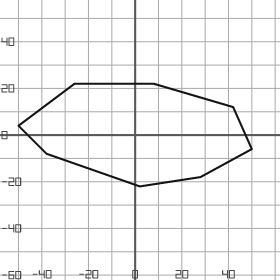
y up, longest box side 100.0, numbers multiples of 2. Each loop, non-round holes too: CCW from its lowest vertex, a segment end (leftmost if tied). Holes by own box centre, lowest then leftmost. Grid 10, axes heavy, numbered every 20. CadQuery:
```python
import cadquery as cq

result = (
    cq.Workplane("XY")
    .moveTo(2.0, -22.0)
    .lineTo(28.0, -18.0)
    .lineTo(50.0, -6.0)
    .lineTo(42.0, 12.0)
    .lineTo(8.0, 22.0)
    .lineTo(-26.0, 22.0)
    .lineTo(-50.0, 4.0)
    .lineTo(-38.0, -8.0)
    .close()
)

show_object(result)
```